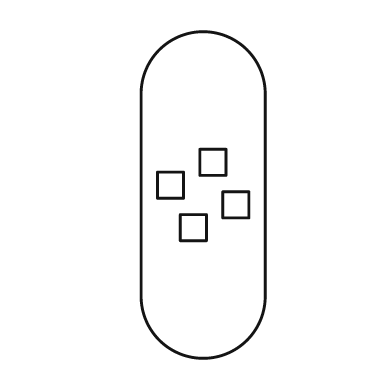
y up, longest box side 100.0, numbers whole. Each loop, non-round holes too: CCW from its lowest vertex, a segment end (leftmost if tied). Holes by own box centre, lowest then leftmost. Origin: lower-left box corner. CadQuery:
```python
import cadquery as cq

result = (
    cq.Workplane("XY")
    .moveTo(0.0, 19.0)
    .threePointArc((19.0, 0.0), (38.0, 19.0))
    .lineTo(38.0, 81.0)
    .threePointArc((19.0, 100.0), (0.0, 81.0))
    .close()
    .moveTo(12.0, 36.0)
    .lineTo(20.0, 36.0)
    .lineTo(20.0, 44.0)
    .lineTo(12.0, 44.0)
    .close()
    .moveTo(25.0, 43.0)
    .lineTo(33.0, 43.0)
    .lineTo(33.0, 51.0)
    .lineTo(25.0, 51.0)
    .close()
    .moveTo(5.0, 49.0)
    .lineTo(13.0, 49.0)
    .lineTo(13.0, 57.0)
    .lineTo(5.0, 57.0)
    .close()
    .moveTo(18.0, 56.0)
    .lineTo(26.0, 56.0)
    .lineTo(26.0, 64.0)
    .lineTo(18.0, 64.0)
    .close()
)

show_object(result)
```